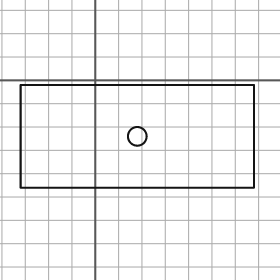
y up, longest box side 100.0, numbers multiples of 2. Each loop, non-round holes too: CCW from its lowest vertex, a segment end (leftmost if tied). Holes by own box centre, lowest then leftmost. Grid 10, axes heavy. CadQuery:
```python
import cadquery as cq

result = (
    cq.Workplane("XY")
    .moveTo(-32.0, -46.0)
    .lineTo(68.0, -46.0)
    .lineTo(68.0, -2.0)
    .lineTo(-32.0, -2.0)
    .close()
    .moveTo(18.0, -24.0)
    .circle(4.0)
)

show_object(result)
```